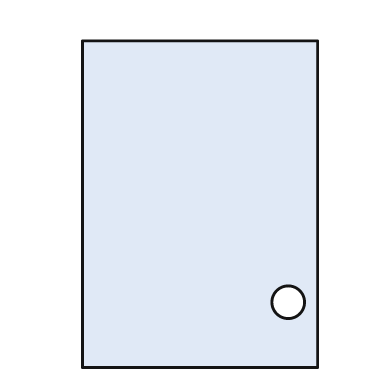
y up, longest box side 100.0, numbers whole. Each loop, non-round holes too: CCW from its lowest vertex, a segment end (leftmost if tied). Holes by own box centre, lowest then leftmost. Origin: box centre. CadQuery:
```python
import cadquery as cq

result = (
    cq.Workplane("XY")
    .moveTo(-36.0, -50.0)
    .lineTo(36.0, -50.0)
    .lineTo(36.0, 50.0)
    .lineTo(-36.0, 50.0)
    .close()
    .moveTo(27.0, -30.0)
    .circle(5.0)
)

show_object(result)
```